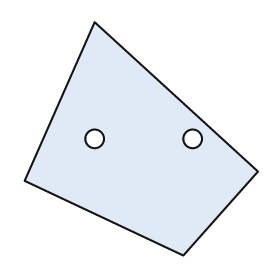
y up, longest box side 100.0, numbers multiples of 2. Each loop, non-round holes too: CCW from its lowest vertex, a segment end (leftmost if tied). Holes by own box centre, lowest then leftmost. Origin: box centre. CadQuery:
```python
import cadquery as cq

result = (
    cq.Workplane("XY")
    .moveTo(18.0, -50.0)
    .lineTo(50.0, -14.0)
    .lineTo(-20.0, 50.0)
    .lineTo(-50.0, -18.0)
    .close()
    .moveTo(-20.0, 0.0)
    .circle(4.0)
    .moveTo(22.0, 0.0)
    .circle(4.0)
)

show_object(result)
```